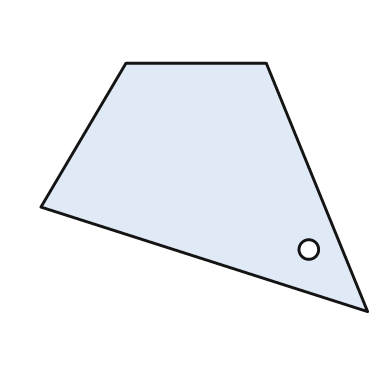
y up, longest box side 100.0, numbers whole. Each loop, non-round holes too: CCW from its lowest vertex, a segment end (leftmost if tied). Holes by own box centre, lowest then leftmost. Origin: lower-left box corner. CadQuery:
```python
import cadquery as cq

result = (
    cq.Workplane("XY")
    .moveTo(100.0, 0.0)
    .lineTo(69.0, 76.0)
    .lineTo(26.0, 76.0)
    .lineTo(0.0, 32.0)
    .close()
    .moveTo(82.0, 19.0)
    .circle(3.0)
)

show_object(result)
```